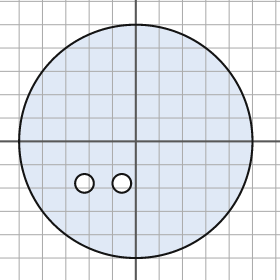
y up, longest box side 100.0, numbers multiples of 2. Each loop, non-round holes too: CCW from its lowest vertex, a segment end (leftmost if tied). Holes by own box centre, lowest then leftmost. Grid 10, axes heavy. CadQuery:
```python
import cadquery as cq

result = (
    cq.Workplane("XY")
    .moveTo(0.0, 0.0)
    .circle(50.0)
    .moveTo(-22.0, -18.0)
    .circle(4.0)
    .moveTo(-6.0, -18.0)
    .circle(4.0)
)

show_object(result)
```